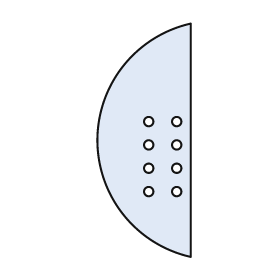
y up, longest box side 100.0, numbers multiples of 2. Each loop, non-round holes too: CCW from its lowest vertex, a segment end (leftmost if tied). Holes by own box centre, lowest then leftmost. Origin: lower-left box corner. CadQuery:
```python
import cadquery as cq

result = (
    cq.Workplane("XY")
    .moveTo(40.0, 0.0)
    .lineTo(40.0, 100.0)
    .threePointArc((0.0, 50.0), (40.0, 0.0))
    .close()
    .moveTo(22.0, 28.0)
    .circle(2.0)
    .moveTo(34.0, 28.0)
    .circle(2.0)
    .moveTo(22.0, 38.0)
    .circle(2.0)
    .moveTo(34.0, 38.0)
    .circle(2.0)
    .moveTo(22.0, 48.0)
    .circle(2.0)
    .moveTo(34.0, 48.0)
    .circle(2.0)
    .moveTo(22.0, 58.0)
    .circle(2.0)
    .moveTo(34.0, 58.0)
    .circle(2.0)
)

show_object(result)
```